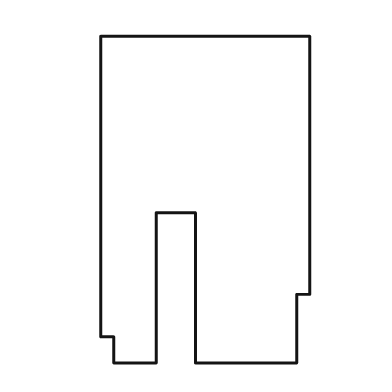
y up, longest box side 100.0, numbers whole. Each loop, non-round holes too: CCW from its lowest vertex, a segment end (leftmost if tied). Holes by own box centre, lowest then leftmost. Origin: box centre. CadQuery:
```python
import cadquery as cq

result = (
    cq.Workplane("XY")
    .moveTo(-28.0, -50.0)
    .lineTo(-15.0, -50.0)
    .lineTo(-15.0, -4.0)
    .lineTo(-3.0, -4.0)
    .lineTo(-3.0, -50.0)
    .lineTo(28.0, -50.0)
    .lineTo(28.0, -29.0)
    .lineTo(32.0, -29.0)
    .lineTo(32.0, 50.0)
    .lineTo(-32.0, 50.0)
    .lineTo(-32.0, -42.0)
    .lineTo(-28.0, -42.0)
    .close()
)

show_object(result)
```